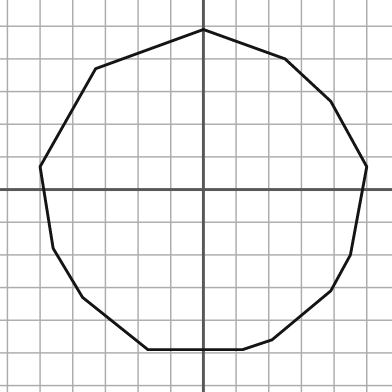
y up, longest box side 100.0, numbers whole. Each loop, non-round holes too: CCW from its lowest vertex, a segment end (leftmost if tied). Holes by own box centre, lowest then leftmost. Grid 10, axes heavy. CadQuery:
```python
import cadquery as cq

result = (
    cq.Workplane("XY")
    .moveTo(-17.0, -49.0)
    .lineTo(12.0, -49.0)
    .lineTo(21.0, -46.0)
    .lineTo(39.0, -31.0)
    .lineTo(45.0, -20.0)
    .lineTo(50.0, 7.0)
    .lineTo(39.0, 27.0)
    .lineTo(25.0, 40.0)
    .lineTo(0.0, 49.0)
    .lineTo(-33.0, 37.0)
    .lineTo(-50.0, 7.0)
    .lineTo(-46.0, -18.0)
    .lineTo(-37.0, -33.0)
    .close()
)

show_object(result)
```